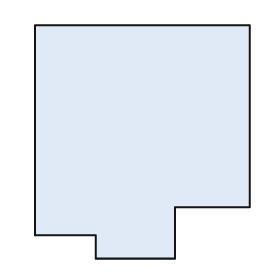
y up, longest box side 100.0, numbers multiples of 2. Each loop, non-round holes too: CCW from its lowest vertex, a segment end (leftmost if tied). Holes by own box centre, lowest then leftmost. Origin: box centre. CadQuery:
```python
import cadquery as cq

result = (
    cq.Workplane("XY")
    .moveTo(-20.0, -50.0)
    .lineTo(14.0, -50.0)
    .lineTo(14.0, -28.0)
    .lineTo(46.0, -28.0)
    .lineTo(46.0, 50.0)
    .lineTo(-46.0, 50.0)
    .lineTo(-46.0, -40.0)
    .lineTo(-20.0, -40.0)
    .close()
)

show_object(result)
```